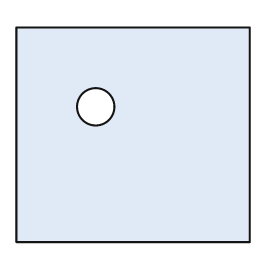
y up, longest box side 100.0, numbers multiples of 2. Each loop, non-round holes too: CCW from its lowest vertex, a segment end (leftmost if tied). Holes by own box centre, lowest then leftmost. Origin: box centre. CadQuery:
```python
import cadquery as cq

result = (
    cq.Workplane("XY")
    .moveTo(-50.0, -46.0)
    .lineTo(50.0, -46.0)
    .lineTo(50.0, 46.0)
    .lineTo(-50.0, 46.0)
    .close()
    .moveTo(-16.0, 12.0)
    .circle(8.0)
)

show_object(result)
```